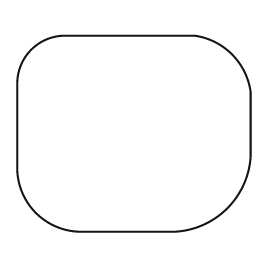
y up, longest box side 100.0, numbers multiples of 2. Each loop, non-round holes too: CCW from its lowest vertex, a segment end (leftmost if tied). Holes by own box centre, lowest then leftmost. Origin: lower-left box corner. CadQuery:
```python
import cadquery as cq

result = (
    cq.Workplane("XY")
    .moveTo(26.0, 0.0)
    .lineTo(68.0, 0.0)
    .threePointArc((90.0, 10.0), (100.0, 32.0))
    .lineTo(100.0, 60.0)
    .threePointArc((92.0, 76.0), (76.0, 84.0))
    .lineTo(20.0, 84.0)
    .threePointArc((6.0, 78.0), (0.0, 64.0))
    .lineTo(0.0, 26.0)
    .threePointArc((8.0, 8.0), (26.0, 0.0))
    .close()
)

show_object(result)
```